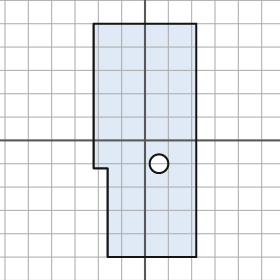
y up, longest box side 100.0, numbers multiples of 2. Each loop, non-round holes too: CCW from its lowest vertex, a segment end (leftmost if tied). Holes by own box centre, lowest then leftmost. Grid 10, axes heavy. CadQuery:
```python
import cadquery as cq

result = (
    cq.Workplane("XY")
    .moveTo(-16.0, -50.0)
    .lineTo(22.0, -50.0)
    .lineTo(22.0, 50.0)
    .lineTo(-22.0, 50.0)
    .lineTo(-22.0, -12.0)
    .lineTo(-16.0, -12.0)
    .close()
    .moveTo(6.0, -10.0)
    .circle(4.0)
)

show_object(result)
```